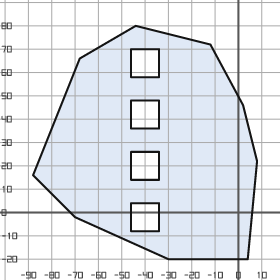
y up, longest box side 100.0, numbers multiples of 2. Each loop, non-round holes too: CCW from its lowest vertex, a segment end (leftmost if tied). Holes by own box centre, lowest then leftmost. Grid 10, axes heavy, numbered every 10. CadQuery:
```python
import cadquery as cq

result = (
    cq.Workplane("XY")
    .moveTo(-30.0, -20.0)
    .lineTo(4.0, -20.0)
    .lineTo(8.0, 22.0)
    .lineTo(2.0, 46.0)
    .lineTo(-12.0, 72.0)
    .lineTo(-44.0, 80.0)
    .lineTo(-68.0, 66.0)
    .lineTo(-88.0, 16.0)
    .lineTo(-70.0, -2.0)
    .close()
    .moveTo(-46.0, -8.0)
    .lineTo(-34.0, -8.0)
    .lineTo(-34.0, 4.0)
    .lineTo(-46.0, 4.0)
    .close()
    .moveTo(-46.0, 14.0)
    .lineTo(-34.0, 14.0)
    .lineTo(-34.0, 26.0)
    .lineTo(-46.0, 26.0)
    .close()
    .moveTo(-46.0, 36.0)
    .lineTo(-34.0, 36.0)
    .lineTo(-34.0, 48.0)
    .lineTo(-46.0, 48.0)
    .close()
    .moveTo(-46.0, 58.0)
    .lineTo(-34.0, 58.0)
    .lineTo(-34.0, 70.0)
    .lineTo(-46.0, 70.0)
    .close()
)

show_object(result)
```